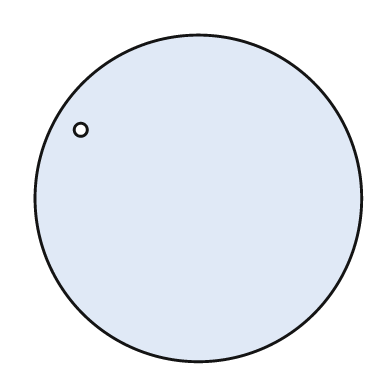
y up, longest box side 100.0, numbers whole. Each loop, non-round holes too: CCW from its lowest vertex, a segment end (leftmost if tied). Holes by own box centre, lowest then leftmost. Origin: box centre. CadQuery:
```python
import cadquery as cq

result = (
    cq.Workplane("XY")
    .moveTo(0.0, 0.0)
    .circle(50.0)
    .moveTo(-36.0, 21.0)
    .circle(2.0)
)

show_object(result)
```